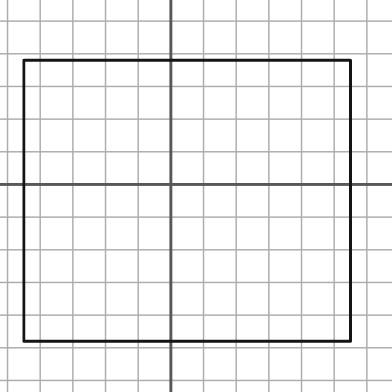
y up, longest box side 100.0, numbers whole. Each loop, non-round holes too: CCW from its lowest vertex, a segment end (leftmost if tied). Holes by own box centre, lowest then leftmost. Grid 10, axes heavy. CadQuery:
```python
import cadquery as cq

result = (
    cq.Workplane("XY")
    .moveTo(-45.0, -48.0)
    .lineTo(55.0, -48.0)
    .lineTo(55.0, 38.0)
    .lineTo(-45.0, 38.0)
    .close()
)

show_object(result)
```